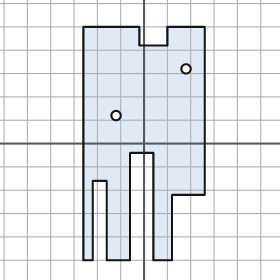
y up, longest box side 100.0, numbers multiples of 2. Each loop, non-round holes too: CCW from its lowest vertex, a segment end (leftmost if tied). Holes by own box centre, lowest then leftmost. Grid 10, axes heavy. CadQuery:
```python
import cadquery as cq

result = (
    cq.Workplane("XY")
    .moveTo(-26.0, -50.0)
    .lineTo(-22.0, -50.0)
    .lineTo(-22.0, -16.0)
    .lineTo(-16.0, -16.0)
    .lineTo(-16.0, -50.0)
    .lineTo(-6.0, -50.0)
    .lineTo(-6.0, -4.0)
    .lineTo(4.0, -4.0)
    .lineTo(4.0, -50.0)
    .lineTo(12.0, -50.0)
    .lineTo(12.0, -22.0)
    .lineTo(26.0, -22.0)
    .lineTo(26.0, 50.0)
    .lineTo(10.0, 50.0)
    .lineTo(10.0, 42.0)
    .lineTo(-2.0, 42.0)
    .lineTo(-2.0, 50.0)
    .lineTo(-26.0, 50.0)
    .close()
    .moveTo(-12.0, 12.0)
    .circle(2.0)
    .moveTo(18.0, 32.0)
    .circle(2.0)
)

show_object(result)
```